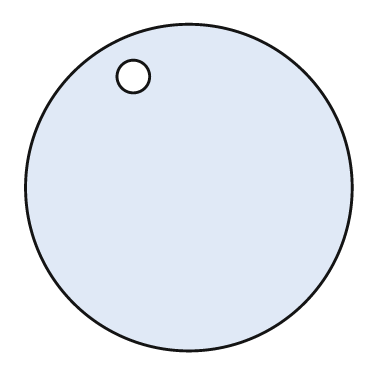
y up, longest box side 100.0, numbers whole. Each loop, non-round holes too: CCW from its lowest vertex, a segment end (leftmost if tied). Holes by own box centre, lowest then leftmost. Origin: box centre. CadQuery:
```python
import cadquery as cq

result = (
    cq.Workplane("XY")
    .moveTo(0.0, 0.0)
    .circle(50.0)
    .moveTo(-17.0, 34.0)
    .circle(5.0)
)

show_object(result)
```